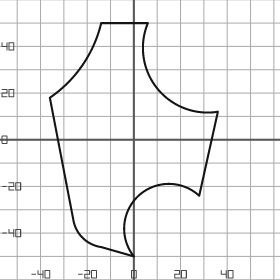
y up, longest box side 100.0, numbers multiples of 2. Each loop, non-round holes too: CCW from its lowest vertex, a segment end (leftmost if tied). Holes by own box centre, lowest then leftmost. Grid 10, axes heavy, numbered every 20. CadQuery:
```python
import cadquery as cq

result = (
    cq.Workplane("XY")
    .moveTo(0.0, -50.0)
    .threePointArc((2.0, -24.0), (28.0, -24.0))
    .lineTo(36.0, 12.0)
    .threePointArc((10.0, 22.0), (6.0, 50.0))
    .lineTo(-14.0, 50.0)
    .threePointArc((-22.0, 32.0), (-36.0, 18.0))
    .lineTo(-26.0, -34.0)
    .threePointArc((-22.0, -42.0), (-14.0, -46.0))
    .close()
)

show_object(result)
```